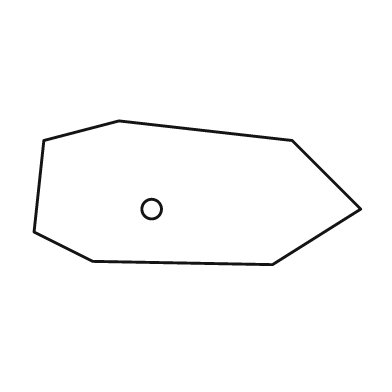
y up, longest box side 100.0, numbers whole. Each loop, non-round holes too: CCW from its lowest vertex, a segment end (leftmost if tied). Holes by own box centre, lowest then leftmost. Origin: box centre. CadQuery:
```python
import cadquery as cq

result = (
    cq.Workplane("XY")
    .moveTo(23.0, -22.0)
    .lineTo(50.0, -5.0)
    .lineTo(29.0, 16.0)
    .lineTo(-24.0, 22.0)
    .lineTo(-47.0, 16.0)
    .lineTo(-50.0, -12.0)
    .lineTo(-32.0, -21.0)
    .close()
    .moveTo(-14.0, -5.0)
    .circle(3.0)
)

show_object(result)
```